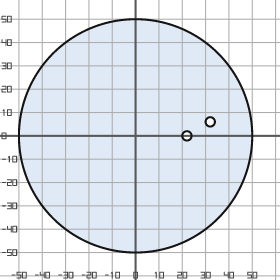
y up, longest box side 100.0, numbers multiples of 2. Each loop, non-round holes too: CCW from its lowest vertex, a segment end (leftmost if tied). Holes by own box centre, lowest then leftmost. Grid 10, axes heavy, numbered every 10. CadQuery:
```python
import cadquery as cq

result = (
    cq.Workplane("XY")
    .moveTo(0.0, 0.0)
    .circle(50.0)
    .moveTo(22.0, 0.0)
    .circle(2.0)
    .moveTo(32.0, 6.0)
    .circle(2.0)
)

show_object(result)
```